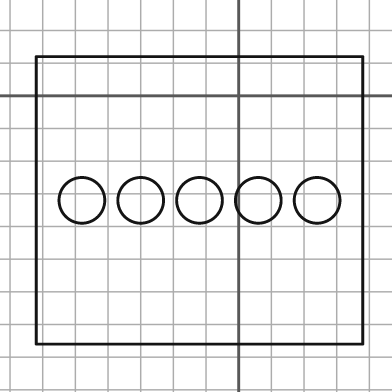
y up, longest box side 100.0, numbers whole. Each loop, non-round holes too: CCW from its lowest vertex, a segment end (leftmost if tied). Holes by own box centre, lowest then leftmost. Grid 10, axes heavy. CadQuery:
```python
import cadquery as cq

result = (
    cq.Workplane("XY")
    .moveTo(-62.0, -76.0)
    .lineTo(38.0, -76.0)
    .lineTo(38.0, 12.0)
    .lineTo(-62.0, 12.0)
    .close()
    .moveTo(-48.0, -32.0)
    .circle(7.0)
    .moveTo(-30.0, -32.0)
    .circle(7.0)
    .moveTo(-12.0, -32.0)
    .circle(7.0)
    .moveTo(6.0, -32.0)
    .circle(7.0)
    .moveTo(24.0, -32.0)
    .circle(7.0)
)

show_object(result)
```